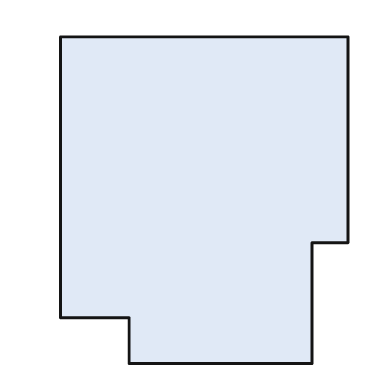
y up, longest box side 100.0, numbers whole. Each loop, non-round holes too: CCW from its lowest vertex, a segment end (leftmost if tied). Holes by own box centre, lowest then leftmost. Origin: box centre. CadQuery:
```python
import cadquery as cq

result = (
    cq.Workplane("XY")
    .moveTo(-23.0, -50.0)
    .lineTo(33.0, -50.0)
    .lineTo(33.0, -13.0)
    .lineTo(44.0, -13.0)
    .lineTo(44.0, 50.0)
    .lineTo(-44.0, 50.0)
    .lineTo(-44.0, -36.0)
    .lineTo(-23.0, -36.0)
    .close()
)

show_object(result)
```